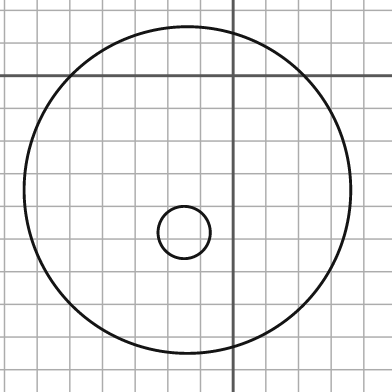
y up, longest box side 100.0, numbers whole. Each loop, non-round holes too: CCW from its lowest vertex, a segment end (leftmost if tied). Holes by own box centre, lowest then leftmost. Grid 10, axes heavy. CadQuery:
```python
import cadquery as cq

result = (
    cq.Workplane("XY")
    .moveTo(-14.0, -35.0)
    .circle(50.0)
    .moveTo(-15.0, -48.0)
    .circle(8.0)
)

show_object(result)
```